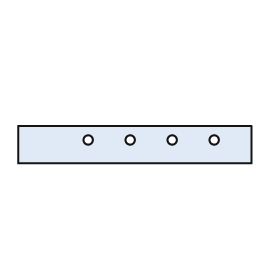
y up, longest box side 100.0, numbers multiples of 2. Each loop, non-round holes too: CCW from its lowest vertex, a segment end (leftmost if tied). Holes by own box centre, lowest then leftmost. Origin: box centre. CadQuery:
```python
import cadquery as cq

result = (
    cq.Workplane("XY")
    .moveTo(-50.0, -8.0)
    .lineTo(50.0, -8.0)
    .lineTo(50.0, 8.0)
    .lineTo(-50.0, 8.0)
    .close()
    .moveTo(-20.0, 2.0)
    .circle(2.0)
    .moveTo(-2.0, 2.0)
    .circle(2.0)
    .moveTo(16.0, 2.0)
    .circle(2.0)
    .moveTo(34.0, 2.0)
    .circle(2.0)
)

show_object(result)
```